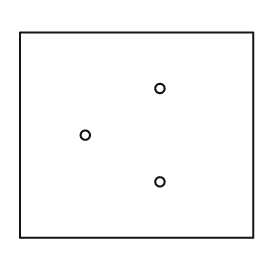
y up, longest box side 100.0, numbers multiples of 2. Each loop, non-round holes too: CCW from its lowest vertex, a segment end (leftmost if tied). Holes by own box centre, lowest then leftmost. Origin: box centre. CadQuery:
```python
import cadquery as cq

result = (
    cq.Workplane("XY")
    .moveTo(-50.0, -44.0)
    .lineTo(50.0, -44.0)
    .lineTo(50.0, 44.0)
    .lineTo(-50.0, 44.0)
    .close()
    .moveTo(10.0, -20.0)
    .circle(2.0)
    .moveTo(-22.0, 0.0)
    .circle(2.0)
    .moveTo(10.0, 20.0)
    .circle(2.0)
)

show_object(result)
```